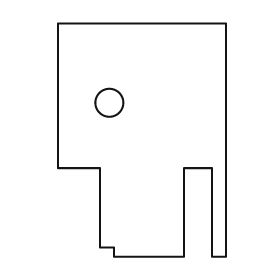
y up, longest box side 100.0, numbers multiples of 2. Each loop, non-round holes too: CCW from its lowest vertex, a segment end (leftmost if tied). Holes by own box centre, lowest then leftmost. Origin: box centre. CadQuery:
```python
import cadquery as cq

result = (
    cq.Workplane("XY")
    .moveTo(-12.0, -50.0)
    .lineTo(18.0, -50.0)
    .lineTo(18.0, -12.0)
    .lineTo(30.0, -12.0)
    .lineTo(30.0, -50.0)
    .lineTo(36.0, -50.0)
    .lineTo(36.0, 50.0)
    .lineTo(-36.0, 50.0)
    .lineTo(-36.0, -12.0)
    .lineTo(-18.0, -12.0)
    .lineTo(-18.0, -46.0)
    .lineTo(-12.0, -46.0)
    .close()
    .moveTo(-14.0, 16.0)
    .circle(6.0)
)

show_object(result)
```